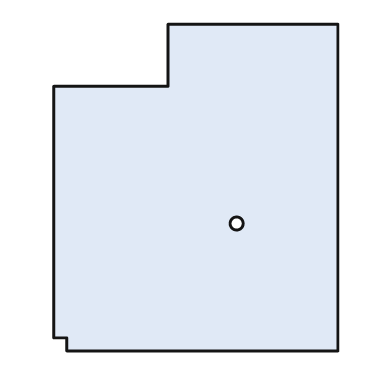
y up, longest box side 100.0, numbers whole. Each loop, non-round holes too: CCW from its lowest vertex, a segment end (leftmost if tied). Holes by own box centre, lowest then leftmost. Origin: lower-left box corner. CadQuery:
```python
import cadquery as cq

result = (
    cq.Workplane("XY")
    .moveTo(4.0, 0.0)
    .lineTo(87.0, 0.0)
    .lineTo(87.0, 100.0)
    .lineTo(35.0, 100.0)
    .lineTo(35.0, 81.0)
    .lineTo(0.0, 81.0)
    .lineTo(0.0, 4.0)
    .lineTo(4.0, 4.0)
    .close()
    .moveTo(56.0, 39.0)
    .circle(2.0)
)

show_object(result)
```